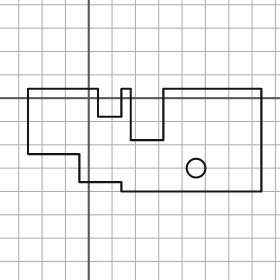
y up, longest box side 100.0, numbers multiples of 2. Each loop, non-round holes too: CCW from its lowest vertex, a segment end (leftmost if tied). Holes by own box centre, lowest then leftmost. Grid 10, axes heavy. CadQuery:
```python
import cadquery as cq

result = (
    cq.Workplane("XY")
    .moveTo(14.0, -40.0)
    .lineTo(74.0, -40.0)
    .lineTo(74.0, 4.0)
    .lineTo(32.0, 4.0)
    .lineTo(32.0, -18.0)
    .lineTo(18.0, -18.0)
    .lineTo(18.0, 4.0)
    .lineTo(14.0, 4.0)
    .lineTo(14.0, -8.0)
    .lineTo(4.0, -8.0)
    .lineTo(4.0, 4.0)
    .lineTo(-26.0, 4.0)
    .lineTo(-26.0, -24.0)
    .lineTo(-4.0, -24.0)
    .lineTo(-4.0, -36.0)
    .lineTo(14.0, -36.0)
    .close()
    .moveTo(46.0, -30.0)
    .circle(4.0)
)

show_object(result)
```